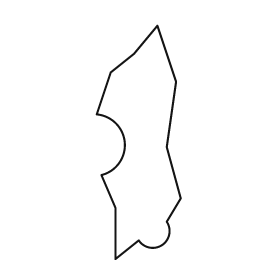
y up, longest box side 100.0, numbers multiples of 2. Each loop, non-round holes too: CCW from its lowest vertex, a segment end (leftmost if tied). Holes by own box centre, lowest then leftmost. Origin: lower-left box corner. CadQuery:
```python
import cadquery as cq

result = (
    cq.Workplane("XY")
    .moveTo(8.0, 0.0)
    .lineTo(18.0, 8.0)
    .threePointArc((28.0, 6.0), (30.0, 16.0))
    .lineTo(36.0, 26.0)
    .lineTo(30.0, 48.0)
    .lineTo(34.0, 76.0)
    .lineTo(26.0, 100.0)
    .lineTo(16.0, 88.0)
    .lineTo(6.0, 80.0)
    .lineTo(0.0, 62.0)
    .threePointArc((12.0, 50.0), (2.0, 36.0))
    .lineTo(8.0, 22.0)
    .close()
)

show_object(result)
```